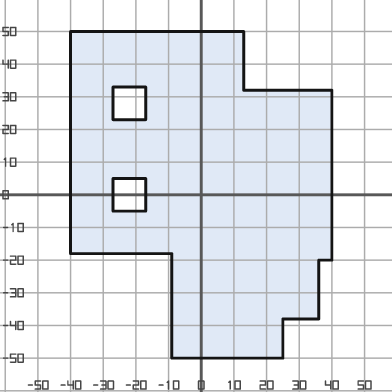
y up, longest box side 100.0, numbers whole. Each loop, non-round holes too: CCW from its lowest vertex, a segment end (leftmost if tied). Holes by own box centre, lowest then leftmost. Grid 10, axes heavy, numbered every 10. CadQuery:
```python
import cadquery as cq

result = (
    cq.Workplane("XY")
    .moveTo(-9.0, -50.0)
    .lineTo(25.0, -50.0)
    .lineTo(25.0, -38.0)
    .lineTo(36.0, -38.0)
    .lineTo(36.0, -20.0)
    .lineTo(40.0, -20.0)
    .lineTo(40.0, 32.0)
    .lineTo(13.0, 32.0)
    .lineTo(13.0, 50.0)
    .lineTo(-40.0, 50.0)
    .lineTo(-40.0, -18.0)
    .lineTo(-9.0, -18.0)
    .close()
    .moveTo(-27.0, -5.0)
    .lineTo(-17.0, -5.0)
    .lineTo(-17.0, 5.0)
    .lineTo(-27.0, 5.0)
    .close()
    .moveTo(-27.0, 23.0)
    .lineTo(-17.0, 23.0)
    .lineTo(-17.0, 33.0)
    .lineTo(-27.0, 33.0)
    .close()
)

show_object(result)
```